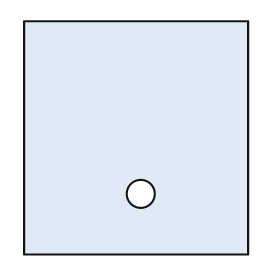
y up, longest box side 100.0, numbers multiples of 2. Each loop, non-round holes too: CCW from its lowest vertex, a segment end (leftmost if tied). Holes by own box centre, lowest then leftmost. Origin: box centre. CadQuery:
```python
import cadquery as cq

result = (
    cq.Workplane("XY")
    .moveTo(-48.0, -50.0)
    .lineTo(48.0, -50.0)
    .lineTo(48.0, 50.0)
    .lineTo(-48.0, 50.0)
    .close()
    .moveTo(2.0, -24.0)
    .circle(6.0)
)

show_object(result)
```